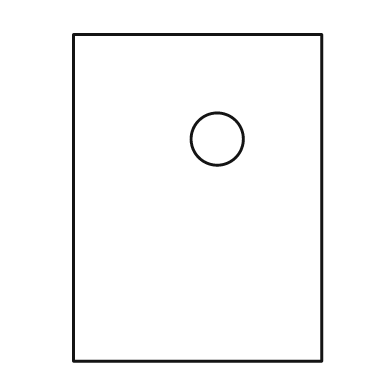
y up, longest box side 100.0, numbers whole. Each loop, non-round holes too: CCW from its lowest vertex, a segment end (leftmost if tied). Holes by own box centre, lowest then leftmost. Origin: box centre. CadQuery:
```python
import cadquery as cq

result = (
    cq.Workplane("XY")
    .moveTo(-38.0, -50.0)
    .lineTo(38.0, -50.0)
    .lineTo(38.0, 50.0)
    .lineTo(-38.0, 50.0)
    .close()
    .moveTo(6.0, 18.0)
    .circle(8.0)
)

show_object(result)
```